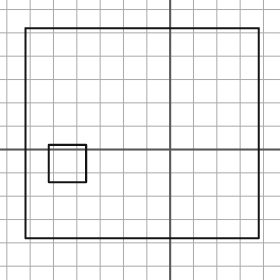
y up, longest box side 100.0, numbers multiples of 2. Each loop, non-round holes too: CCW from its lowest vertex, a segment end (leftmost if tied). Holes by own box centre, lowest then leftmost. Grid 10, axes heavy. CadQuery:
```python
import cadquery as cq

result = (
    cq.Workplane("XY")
    .moveTo(-62.0, -38.0)
    .lineTo(38.0, -38.0)
    .lineTo(38.0, 52.0)
    .lineTo(-62.0, 52.0)
    .close()
    .moveTo(-52.0, -14.0)
    .lineTo(-36.0, -14.0)
    .lineTo(-36.0, 2.0)
    .lineTo(-52.0, 2.0)
    .close()
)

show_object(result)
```